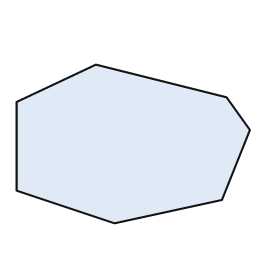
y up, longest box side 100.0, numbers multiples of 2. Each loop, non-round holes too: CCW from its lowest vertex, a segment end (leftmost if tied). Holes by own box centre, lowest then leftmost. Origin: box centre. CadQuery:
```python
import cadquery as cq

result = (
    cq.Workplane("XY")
    .moveTo(-8.0, -34.0)
    .lineTo(38.0, -24.0)
    .lineTo(50.0, 6.0)
    .lineTo(40.0, 20.0)
    .lineTo(-16.0, 34.0)
    .lineTo(-50.0, 18.0)
    .lineTo(-50.0, -20.0)
    .close()
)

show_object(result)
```